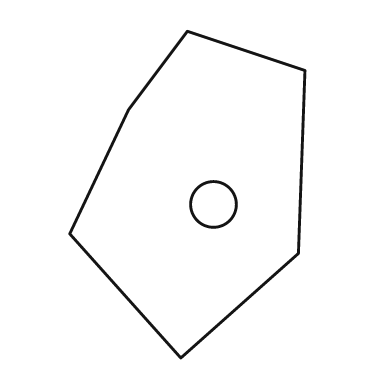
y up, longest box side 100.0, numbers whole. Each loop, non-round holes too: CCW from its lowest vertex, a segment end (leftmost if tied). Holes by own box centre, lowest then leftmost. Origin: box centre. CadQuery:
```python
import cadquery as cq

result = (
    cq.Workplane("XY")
    .moveTo(-2.0, -50.0)
    .lineTo(34.0, -18.0)
    .lineTo(36.0, 38.0)
    .lineTo(0.0, 50.0)
    .lineTo(-18.0, 26.0)
    .lineTo(-36.0, -12.0)
    .close()
    .moveTo(8.0, -3.0)
    .circle(7.0)
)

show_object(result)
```